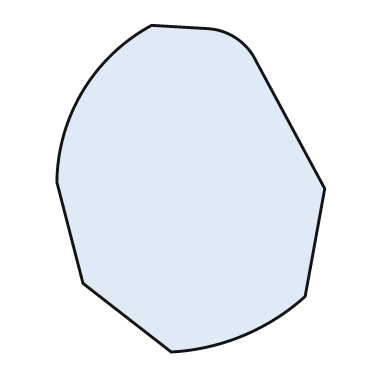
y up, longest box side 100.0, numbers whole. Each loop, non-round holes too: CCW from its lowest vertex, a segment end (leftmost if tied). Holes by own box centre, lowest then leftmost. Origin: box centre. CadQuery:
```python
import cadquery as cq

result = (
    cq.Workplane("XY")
    .moveTo(-6.0, -50.0)
    .threePointArc((16.0, -45.0), (35.0, -33.0))
    .lineTo(41.0, 0.0)
    .lineTo(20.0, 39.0)
    .threePointArc((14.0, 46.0), (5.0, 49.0))
    .lineTo(-12.0, 50.0)
    .threePointArc((-33.0, 30.0), (-41.0, 2.0))
    .lineTo(-33.0, -29.0)
    .close()
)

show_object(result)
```